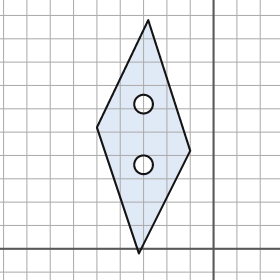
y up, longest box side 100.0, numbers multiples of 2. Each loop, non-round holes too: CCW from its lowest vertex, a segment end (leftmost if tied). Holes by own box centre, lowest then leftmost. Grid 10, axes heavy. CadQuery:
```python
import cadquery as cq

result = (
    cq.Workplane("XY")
    .moveTo(-32.0, -2.0)
    .lineTo(-10.0, 42.0)
    .lineTo(-28.0, 98.0)
    .lineTo(-50.0, 52.0)
    .close()
    .moveTo(-30.0, 36.0)
    .circle(4.0)
    .moveTo(-30.0, 62.0)
    .circle(4.0)
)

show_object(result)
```